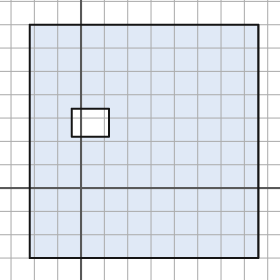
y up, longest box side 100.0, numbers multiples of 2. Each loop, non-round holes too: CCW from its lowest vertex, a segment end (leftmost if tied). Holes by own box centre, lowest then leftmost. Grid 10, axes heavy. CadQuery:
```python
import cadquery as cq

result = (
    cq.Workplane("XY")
    .moveTo(-22.0, -30.0)
    .lineTo(76.0, -30.0)
    .lineTo(76.0, 70.0)
    .lineTo(-22.0, 70.0)
    .close()
    .moveTo(-4.0, 22.0)
    .lineTo(12.0, 22.0)
    .lineTo(12.0, 34.0)
    .lineTo(-4.0, 34.0)
    .close()
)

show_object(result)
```